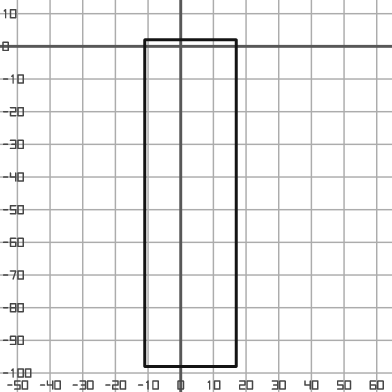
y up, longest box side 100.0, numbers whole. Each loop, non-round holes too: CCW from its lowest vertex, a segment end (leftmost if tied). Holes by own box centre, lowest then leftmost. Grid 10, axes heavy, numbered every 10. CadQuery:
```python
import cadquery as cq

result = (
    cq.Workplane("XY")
    .moveTo(-11.0, -98.0)
    .lineTo(17.0, -98.0)
    .lineTo(17.0, 2.0)
    .lineTo(-11.0, 2.0)
    .close()
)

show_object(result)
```